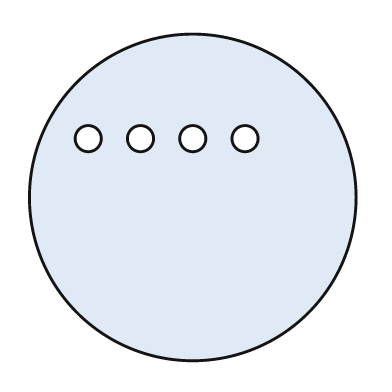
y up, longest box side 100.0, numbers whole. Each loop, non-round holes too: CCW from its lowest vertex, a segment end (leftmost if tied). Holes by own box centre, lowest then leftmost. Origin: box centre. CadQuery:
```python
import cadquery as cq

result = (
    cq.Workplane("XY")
    .moveTo(0.0, 0.0)
    .circle(50.0)
    .moveTo(-32.0, 18.0)
    .circle(4.0)
    .moveTo(-16.0, 18.0)
    .circle(4.0)
    .moveTo(0.0, 18.0)
    .circle(4.0)
    .moveTo(16.0, 18.0)
    .circle(4.0)
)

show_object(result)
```